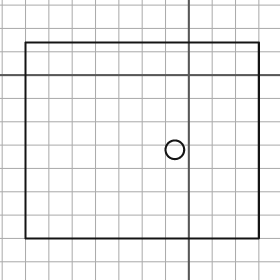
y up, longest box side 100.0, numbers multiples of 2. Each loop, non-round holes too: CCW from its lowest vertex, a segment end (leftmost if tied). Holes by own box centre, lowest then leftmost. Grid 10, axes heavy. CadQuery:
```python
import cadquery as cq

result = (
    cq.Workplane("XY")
    .moveTo(-70.0, -70.0)
    .lineTo(30.0, -70.0)
    .lineTo(30.0, 14.0)
    .lineTo(-70.0, 14.0)
    .close()
    .moveTo(-6.0, -32.0)
    .circle(4.0)
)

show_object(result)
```